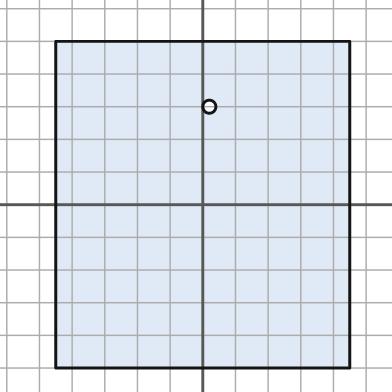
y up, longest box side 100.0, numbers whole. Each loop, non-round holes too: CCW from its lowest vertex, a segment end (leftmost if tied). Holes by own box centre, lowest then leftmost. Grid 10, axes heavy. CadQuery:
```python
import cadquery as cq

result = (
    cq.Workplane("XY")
    .moveTo(-45.0, -50.0)
    .lineTo(45.0, -50.0)
    .lineTo(45.0, 50.0)
    .lineTo(-45.0, 50.0)
    .close()
    .moveTo(2.0, 30.0)
    .circle(2.0)
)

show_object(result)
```